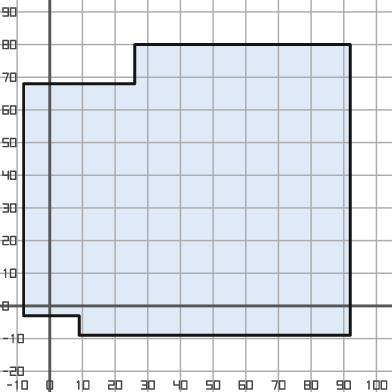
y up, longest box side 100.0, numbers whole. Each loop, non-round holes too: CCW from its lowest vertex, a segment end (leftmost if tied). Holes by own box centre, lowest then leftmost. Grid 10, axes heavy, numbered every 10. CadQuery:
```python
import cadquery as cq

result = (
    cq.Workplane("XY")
    .moveTo(9.0, -9.0)
    .lineTo(92.0, -9.0)
    .lineTo(92.0, 80.0)
    .lineTo(26.0, 80.0)
    .lineTo(26.0, 68.0)
    .lineTo(-8.0, 68.0)
    .lineTo(-8.0, -3.0)
    .lineTo(9.0, -3.0)
    .close()
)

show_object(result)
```